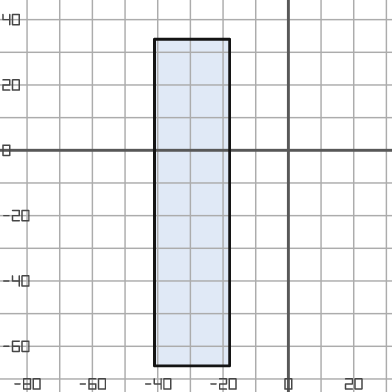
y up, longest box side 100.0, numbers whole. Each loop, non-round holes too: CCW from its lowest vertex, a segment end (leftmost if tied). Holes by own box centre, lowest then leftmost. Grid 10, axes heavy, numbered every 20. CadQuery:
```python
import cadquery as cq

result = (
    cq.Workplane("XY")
    .moveTo(-41.0, -66.0)
    .lineTo(-18.0, -66.0)
    .lineTo(-18.0, 34.0)
    .lineTo(-41.0, 34.0)
    .close()
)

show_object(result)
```